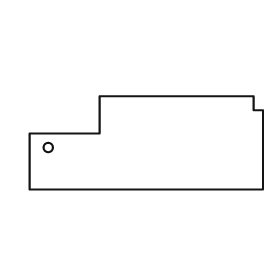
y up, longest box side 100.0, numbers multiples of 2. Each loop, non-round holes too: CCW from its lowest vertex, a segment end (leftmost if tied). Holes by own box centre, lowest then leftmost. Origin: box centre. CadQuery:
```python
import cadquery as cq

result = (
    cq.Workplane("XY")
    .moveTo(-50.0, -20.0)
    .lineTo(50.0, -20.0)
    .lineTo(50.0, 14.0)
    .lineTo(46.0, 14.0)
    .lineTo(46.0, 20.0)
    .lineTo(-20.0, 20.0)
    .lineTo(-20.0, 4.0)
    .lineTo(-50.0, 4.0)
    .close()
    .moveTo(-42.0, -2.0)
    .circle(2.0)
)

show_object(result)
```